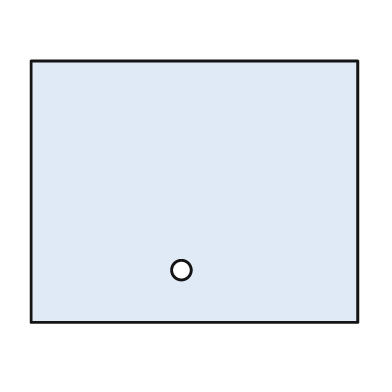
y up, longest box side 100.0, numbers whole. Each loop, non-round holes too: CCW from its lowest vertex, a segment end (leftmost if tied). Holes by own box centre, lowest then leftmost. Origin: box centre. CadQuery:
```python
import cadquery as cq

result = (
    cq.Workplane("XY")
    .moveTo(-50.0, -40.0)
    .lineTo(50.0, -40.0)
    .lineTo(50.0, 40.0)
    .lineTo(-50.0, 40.0)
    .close()
    .moveTo(-4.0, -24.0)
    .circle(3.0)
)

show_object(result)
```